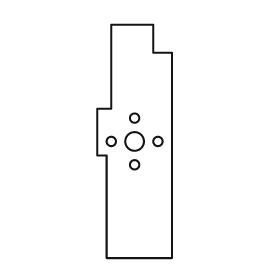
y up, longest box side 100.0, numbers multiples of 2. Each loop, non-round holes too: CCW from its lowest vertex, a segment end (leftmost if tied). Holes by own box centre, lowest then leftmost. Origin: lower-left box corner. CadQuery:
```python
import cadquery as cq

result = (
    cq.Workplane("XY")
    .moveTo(4.0, 0.0)
    .lineTo(32.0, 0.0)
    .lineTo(32.0, 88.0)
    .lineTo(24.0, 88.0)
    .lineTo(24.0, 100.0)
    .lineTo(6.0, 100.0)
    .lineTo(6.0, 64.0)
    .lineTo(0.0, 64.0)
    .lineTo(0.0, 44.0)
    .lineTo(4.0, 44.0)
    .close()
    .moveTo(16.0, 40.0)
    .circle(2.0)
    .moveTo(6.0, 50.0)
    .circle(2.0)
    .moveTo(16.0, 50.0)
    .circle(4.0)
    .moveTo(26.0, 50.0)
    .circle(2.0)
    .moveTo(16.0, 60.0)
    .circle(2.0)
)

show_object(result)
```